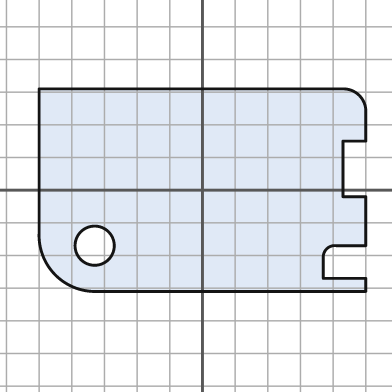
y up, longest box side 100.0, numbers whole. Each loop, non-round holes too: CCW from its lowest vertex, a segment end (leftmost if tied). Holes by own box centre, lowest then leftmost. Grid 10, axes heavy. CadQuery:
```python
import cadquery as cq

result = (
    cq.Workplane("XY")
    .moveTo(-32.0, -31.0)
    .lineTo(50.0, -31.0)
    .lineTo(50.0, -27.0)
    .lineTo(37.0, -27.0)
    .lineTo(37.0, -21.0)
    .threePointArc((38.0, -18.0), (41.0, -17.0))
    .lineTo(50.0, -17.0)
    .lineTo(50.0, -2.0)
    .lineTo(43.0, -2.0)
    .lineTo(43.0, 15.0)
    .lineTo(50.0, 15.0)
    .lineTo(50.0, 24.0)
    .threePointArc((48.0, 29.0), (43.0, 31.0))
    .lineTo(-50.0, 31.0)
    .lineTo(-50.0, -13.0)
    .threePointArc((-45.0, -26.0), (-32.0, -31.0))
    .close()
    .moveTo(-33.0, -17.0)
    .circle(6.0)
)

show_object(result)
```